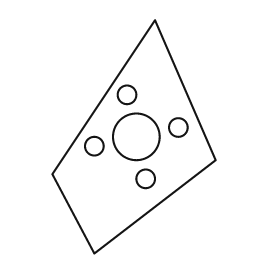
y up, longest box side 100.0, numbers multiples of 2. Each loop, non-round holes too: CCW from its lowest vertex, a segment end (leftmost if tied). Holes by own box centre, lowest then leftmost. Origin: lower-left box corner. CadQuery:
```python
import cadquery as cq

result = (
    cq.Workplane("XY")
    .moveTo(18.0, 0.0)
    .lineTo(70.0, 40.0)
    .lineTo(44.0, 100.0)
    .lineTo(0.0, 34.0)
    .close()
    .moveTo(40.0, 32.0)
    .circle(4.0)
    .moveTo(18.0, 46.0)
    .circle(4.0)
    .moveTo(36.0, 50.0)
    .circle(10.0)
    .moveTo(54.0, 54.0)
    .circle(4.0)
    .moveTo(32.0, 68.0)
    .circle(4.0)
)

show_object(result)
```